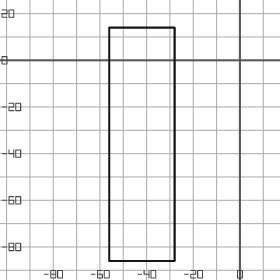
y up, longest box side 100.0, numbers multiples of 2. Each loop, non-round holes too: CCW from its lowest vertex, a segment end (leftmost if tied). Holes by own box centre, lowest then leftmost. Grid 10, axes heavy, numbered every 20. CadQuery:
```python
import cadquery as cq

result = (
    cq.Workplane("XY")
    .moveTo(-56.0, -86.0)
    .lineTo(-28.0, -86.0)
    .lineTo(-28.0, 14.0)
    .lineTo(-56.0, 14.0)
    .close()
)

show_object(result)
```